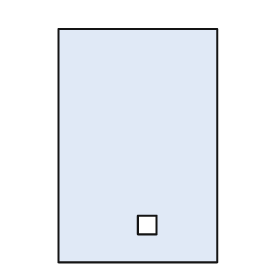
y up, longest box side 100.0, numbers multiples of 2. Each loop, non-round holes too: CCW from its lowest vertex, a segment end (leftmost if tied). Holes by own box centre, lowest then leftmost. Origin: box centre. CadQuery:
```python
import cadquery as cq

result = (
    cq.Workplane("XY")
    .moveTo(-34.0, -50.0)
    .lineTo(34.0, -50.0)
    .lineTo(34.0, 50.0)
    .lineTo(-34.0, 50.0)
    .close()
    .moveTo(0.0, -38.0)
    .lineTo(8.0, -38.0)
    .lineTo(8.0, -30.0)
    .lineTo(0.0, -30.0)
    .close()
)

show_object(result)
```